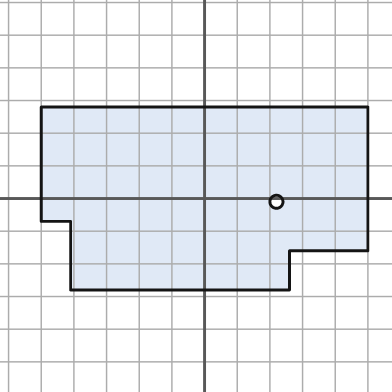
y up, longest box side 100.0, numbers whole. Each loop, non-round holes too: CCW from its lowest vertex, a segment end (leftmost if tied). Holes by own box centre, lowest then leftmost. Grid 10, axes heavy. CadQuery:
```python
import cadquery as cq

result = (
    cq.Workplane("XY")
    .moveTo(-41.0, -28.0)
    .lineTo(26.0, -28.0)
    .lineTo(26.0, -16.0)
    .lineTo(50.0, -16.0)
    .lineTo(50.0, 28.0)
    .lineTo(-50.0, 28.0)
    .lineTo(-50.0, -7.0)
    .lineTo(-41.0, -7.0)
    .close()
    .moveTo(22.0, -1.0)
    .circle(2.0)
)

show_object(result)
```